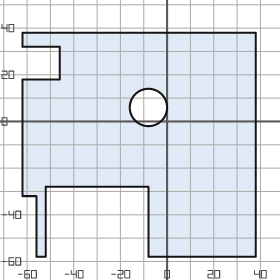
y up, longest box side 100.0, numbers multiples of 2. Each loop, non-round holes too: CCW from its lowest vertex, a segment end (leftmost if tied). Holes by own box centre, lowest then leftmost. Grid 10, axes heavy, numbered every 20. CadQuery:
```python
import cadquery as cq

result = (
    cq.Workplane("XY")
    .moveTo(-56.0, -58.0)
    .lineTo(-52.0, -58.0)
    .lineTo(-52.0, -28.0)
    .lineTo(-8.0, -28.0)
    .lineTo(-8.0, -58.0)
    .lineTo(38.0, -58.0)
    .lineTo(38.0, 38.0)
    .lineTo(-62.0, 38.0)
    .lineTo(-62.0, 32.0)
    .lineTo(-46.0, 32.0)
    .lineTo(-46.0, 18.0)
    .lineTo(-62.0, 18.0)
    .lineTo(-62.0, -32.0)
    .lineTo(-56.0, -32.0)
    .close()
    .moveTo(-8.0, 6.0)
    .circle(8.0)
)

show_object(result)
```